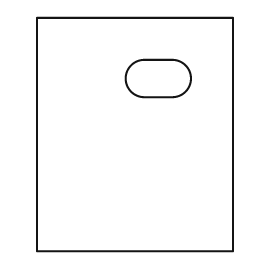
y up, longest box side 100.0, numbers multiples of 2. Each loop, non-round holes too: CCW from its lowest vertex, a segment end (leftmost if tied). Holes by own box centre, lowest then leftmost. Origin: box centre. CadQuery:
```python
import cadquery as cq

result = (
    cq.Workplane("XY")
    .moveTo(-42.0, -50.0)
    .lineTo(42.0, -50.0)
    .lineTo(42.0, 50.0)
    .lineTo(-42.0, 50.0)
    .close()
    .moveTo(4.0, 16.0)
    .lineTo(16.0, 16.0)
    .threePointArc((24.0, 24.0), (16.0, 32.0))
    .lineTo(4.0, 32.0)
    .threePointArc((-4.0, 24.0), (4.0, 16.0))
    .close()
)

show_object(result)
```